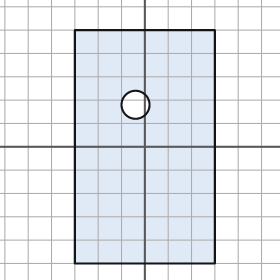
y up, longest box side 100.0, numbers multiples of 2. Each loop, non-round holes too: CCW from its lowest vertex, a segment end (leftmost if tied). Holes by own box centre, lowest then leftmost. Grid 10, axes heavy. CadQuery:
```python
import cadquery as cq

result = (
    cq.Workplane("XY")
    .moveTo(-30.0, -50.0)
    .lineTo(30.0, -50.0)
    .lineTo(30.0, 50.0)
    .lineTo(-30.0, 50.0)
    .close()
    .moveTo(-4.0, 18.0)
    .circle(6.0)
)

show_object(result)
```